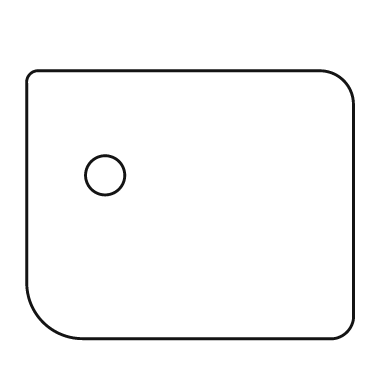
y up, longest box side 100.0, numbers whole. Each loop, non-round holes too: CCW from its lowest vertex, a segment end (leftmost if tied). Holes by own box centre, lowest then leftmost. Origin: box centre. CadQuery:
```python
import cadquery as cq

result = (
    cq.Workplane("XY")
    .moveTo(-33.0, -41.0)
    .lineTo(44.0, -41.0)
    .threePointArc((48.0, -39.0), (50.0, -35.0))
    .lineTo(50.0, 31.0)
    .threePointArc((47.0, 38.0), (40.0, 41.0))
    .lineTo(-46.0, 41.0)
    .threePointArc((-49.0, 40.0), (-50.0, 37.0))
    .lineTo(-50.0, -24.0)
    .threePointArc((-45.0, -36.0), (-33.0, -41.0))
    .close()
    .moveTo(-26.0, 9.0)
    .circle(6.0)
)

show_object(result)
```